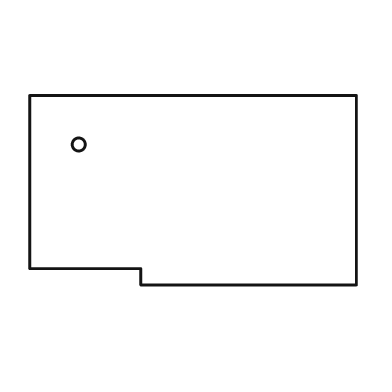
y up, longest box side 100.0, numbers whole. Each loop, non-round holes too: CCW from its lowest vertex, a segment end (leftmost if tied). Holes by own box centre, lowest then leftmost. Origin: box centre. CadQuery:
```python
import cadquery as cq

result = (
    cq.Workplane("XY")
    .moveTo(-16.0, -29.0)
    .lineTo(50.0, -29.0)
    .lineTo(50.0, 29.0)
    .lineTo(-50.0, 29.0)
    .lineTo(-50.0, -24.0)
    .lineTo(-16.0, -24.0)
    .close()
    .moveTo(-35.0, 14.0)
    .circle(2.0)
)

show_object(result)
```